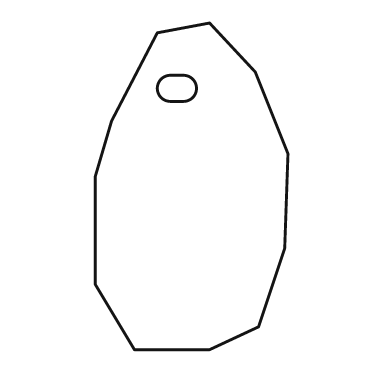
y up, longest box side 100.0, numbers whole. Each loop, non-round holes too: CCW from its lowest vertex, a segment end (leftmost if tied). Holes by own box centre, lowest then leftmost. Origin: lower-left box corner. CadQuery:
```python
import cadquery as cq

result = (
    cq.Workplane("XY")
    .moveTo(12.0, 0.0)
    .lineTo(35.0, 0.0)
    .lineTo(50.0, 7.0)
    .lineTo(58.0, 31.0)
    .lineTo(59.0, 60.0)
    .lineTo(49.0, 85.0)
    .lineTo(35.0, 100.0)
    .lineTo(19.0, 97.0)
    .lineTo(5.0, 70.0)
    .lineTo(0.0, 53.0)
    .lineTo(0.0, 20.0)
    .close()
    .moveTo(23.0, 76.0)
    .lineTo(27.0, 76.0)
    .threePointArc((31.0, 80.0), (27.0, 84.0))
    .lineTo(23.0, 84.0)
    .threePointArc((19.0, 80.0), (23.0, 76.0))
    .close()
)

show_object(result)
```